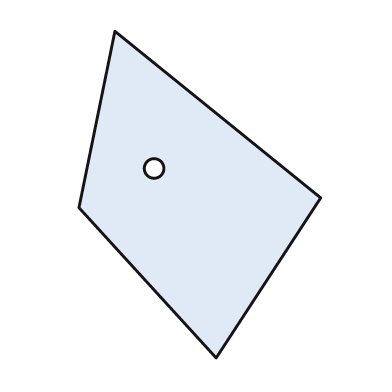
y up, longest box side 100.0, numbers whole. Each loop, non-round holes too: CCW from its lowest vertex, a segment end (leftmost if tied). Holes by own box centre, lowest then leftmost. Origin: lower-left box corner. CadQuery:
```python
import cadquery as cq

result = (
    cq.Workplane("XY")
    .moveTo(42.0, 0.0)
    .lineTo(74.0, 49.0)
    .lineTo(11.0, 100.0)
    .lineTo(0.0, 46.0)
    .close()
    .moveTo(23.0, 58.0)
    .circle(3.0)
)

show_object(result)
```